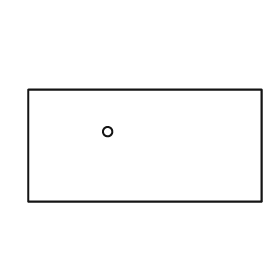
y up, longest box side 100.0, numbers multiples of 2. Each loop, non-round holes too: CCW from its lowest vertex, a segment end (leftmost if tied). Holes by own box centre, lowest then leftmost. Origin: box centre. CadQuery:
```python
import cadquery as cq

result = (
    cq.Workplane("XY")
    .moveTo(-50.0, -24.0)
    .lineTo(50.0, -24.0)
    .lineTo(50.0, 24.0)
    .lineTo(-50.0, 24.0)
    .close()
    .moveTo(-16.0, 6.0)
    .circle(2.0)
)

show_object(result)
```